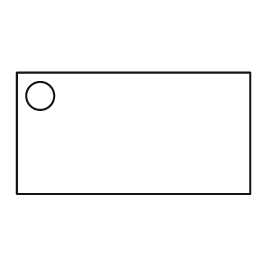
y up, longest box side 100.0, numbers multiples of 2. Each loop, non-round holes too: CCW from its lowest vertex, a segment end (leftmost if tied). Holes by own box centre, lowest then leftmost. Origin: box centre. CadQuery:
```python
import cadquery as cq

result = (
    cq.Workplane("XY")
    .moveTo(-50.0, -26.0)
    .lineTo(50.0, -26.0)
    .lineTo(50.0, 26.0)
    .lineTo(-50.0, 26.0)
    .close()
    .moveTo(-40.0, 16.0)
    .circle(6.0)
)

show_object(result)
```